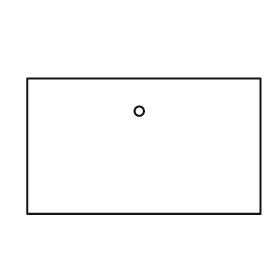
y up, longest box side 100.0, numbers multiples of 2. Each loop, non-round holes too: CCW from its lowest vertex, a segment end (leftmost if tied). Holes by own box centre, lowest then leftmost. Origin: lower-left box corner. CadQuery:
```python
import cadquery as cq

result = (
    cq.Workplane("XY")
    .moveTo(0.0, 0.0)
    .lineTo(100.0, 0.0)
    .lineTo(100.0, 58.0)
    .lineTo(0.0, 58.0)
    .close()
    .moveTo(48.0, 44.0)
    .circle(2.0)
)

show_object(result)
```